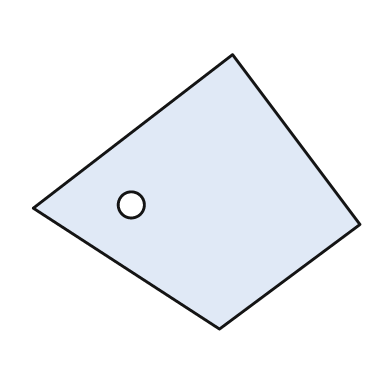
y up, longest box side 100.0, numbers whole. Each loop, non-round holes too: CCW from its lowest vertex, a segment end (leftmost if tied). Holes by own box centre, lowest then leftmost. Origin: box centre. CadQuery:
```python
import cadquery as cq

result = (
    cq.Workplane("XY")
    .moveTo(7.0, -42.0)
    .lineTo(50.0, -10.0)
    .lineTo(11.0, 42.0)
    .lineTo(-50.0, -5.0)
    .close()
    .moveTo(-20.0, -4.0)
    .circle(4.0)
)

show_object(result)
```